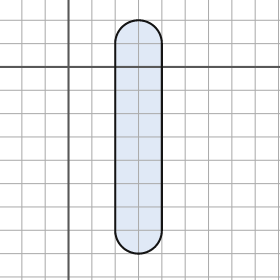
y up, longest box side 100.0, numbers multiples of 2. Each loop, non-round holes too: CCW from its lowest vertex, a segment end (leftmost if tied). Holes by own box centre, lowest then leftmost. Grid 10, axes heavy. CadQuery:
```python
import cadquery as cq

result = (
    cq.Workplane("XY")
    .moveTo(20.0, -70.0)
    .threePointArc((30.0, -80.0), (40.0, -70.0))
    .lineTo(40.0, 10.0)
    .threePointArc((30.0, 20.0), (20.0, 10.0))
    .close()
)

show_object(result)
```